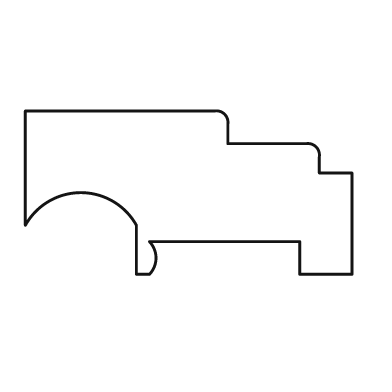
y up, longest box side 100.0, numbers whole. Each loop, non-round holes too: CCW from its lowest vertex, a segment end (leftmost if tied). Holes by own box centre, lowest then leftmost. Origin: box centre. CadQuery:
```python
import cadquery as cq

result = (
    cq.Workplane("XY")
    .moveTo(-16.0, -25.0)
    .lineTo(-12.0, -25.0)
    .threePointArc((-10.0, -20.0), (-12.0, -15.0))
    .lineTo(34.0, -15.0)
    .lineTo(34.0, -25.0)
    .lineTo(50.0, -25.0)
    .lineTo(50.0, 6.0)
    .lineTo(40.0, 6.0)
    .lineTo(40.0, 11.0)
    .threePointArc((39.0, 14.0), (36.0, 15.0))
    .lineTo(12.0, 15.0)
    .lineTo(12.0, 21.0)
    .threePointArc((11.0, 24.0), (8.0, 25.0))
    .lineTo(-50.0, 25.0)
    .lineTo(-50.0, -10.0)
    .threePointArc((-33.0, 0.0), (-16.0, -10.0))
    .close()
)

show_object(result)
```